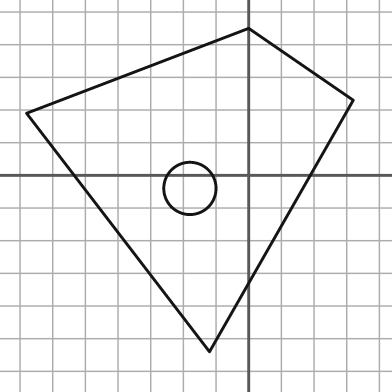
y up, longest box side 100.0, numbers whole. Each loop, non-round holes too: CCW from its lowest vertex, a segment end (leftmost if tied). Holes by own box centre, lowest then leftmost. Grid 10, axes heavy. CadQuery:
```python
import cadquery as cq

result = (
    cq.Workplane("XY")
    .moveTo(-12.0, -54.0)
    .lineTo(32.0, 23.0)
    .lineTo(0.0, 45.0)
    .lineTo(-68.0, 19.0)
    .close()
    .moveTo(-18.0, -4.0)
    .circle(8.0)
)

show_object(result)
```